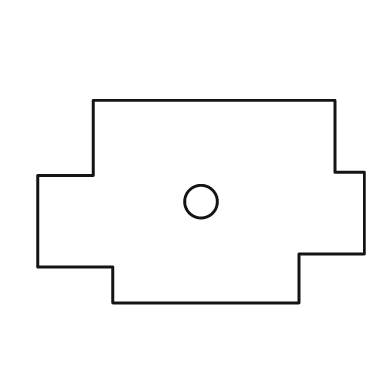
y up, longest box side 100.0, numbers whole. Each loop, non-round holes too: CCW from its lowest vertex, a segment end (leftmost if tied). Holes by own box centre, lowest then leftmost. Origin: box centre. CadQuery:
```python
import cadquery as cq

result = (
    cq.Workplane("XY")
    .moveTo(-27.0, -31.0)
    .lineTo(30.0, -31.0)
    .lineTo(30.0, -16.0)
    .lineTo(50.0, -16.0)
    .lineTo(50.0, 9.0)
    .lineTo(41.0, 9.0)
    .lineTo(41.0, 31.0)
    .lineTo(-33.0, 31.0)
    .lineTo(-33.0, 8.0)
    .lineTo(-50.0, 8.0)
    .lineTo(-50.0, -20.0)
    .lineTo(-27.0, -20.0)
    .close()
    .moveTo(0.0, 0.0)
    .circle(5.0)
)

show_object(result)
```